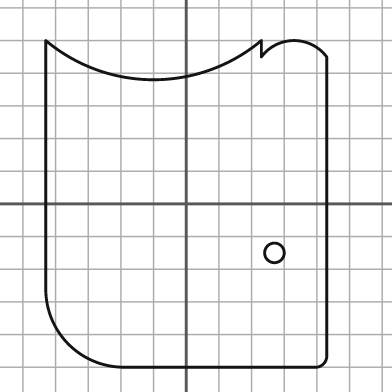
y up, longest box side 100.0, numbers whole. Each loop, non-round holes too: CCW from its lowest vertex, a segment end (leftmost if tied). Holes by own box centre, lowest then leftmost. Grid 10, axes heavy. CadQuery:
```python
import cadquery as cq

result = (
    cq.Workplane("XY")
    .moveTo(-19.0, -50.0)
    .lineTo(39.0, -50.0)
    .threePointArc((42.0, -49.0), (43.0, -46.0))
    .lineTo(43.0, 45.0)
    .threePointArc((33.0, 50.0), (23.0, 45.0))
    .lineTo(23.0, 50.0)
    .threePointArc((-10.0, 38.0), (-43.0, 50.0))
    .lineTo(-43.0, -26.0)
    .threePointArc((-36.0, -43.0), (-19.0, -50.0))
    .close()
    .moveTo(27.0, -15.0)
    .circle(3.0)
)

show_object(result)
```